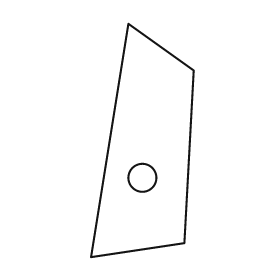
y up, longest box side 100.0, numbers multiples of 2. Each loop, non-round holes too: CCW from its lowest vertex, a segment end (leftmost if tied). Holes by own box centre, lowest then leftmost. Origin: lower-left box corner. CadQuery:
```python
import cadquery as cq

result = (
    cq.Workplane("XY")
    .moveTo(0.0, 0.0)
    .lineTo(40.0, 6.0)
    .lineTo(44.0, 80.0)
    .lineTo(16.0, 100.0)
    .close()
    .moveTo(22.0, 34.0)
    .circle(6.0)
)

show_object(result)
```